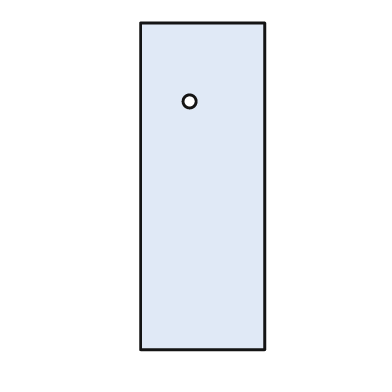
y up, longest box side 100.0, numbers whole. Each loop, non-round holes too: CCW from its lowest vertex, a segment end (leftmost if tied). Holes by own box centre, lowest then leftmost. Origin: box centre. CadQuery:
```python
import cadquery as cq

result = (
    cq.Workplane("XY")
    .moveTo(-19.0, -50.0)
    .lineTo(19.0, -50.0)
    .lineTo(19.0, 50.0)
    .lineTo(-19.0, 50.0)
    .close()
    .moveTo(-4.0, 26.0)
    .circle(2.0)
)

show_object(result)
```